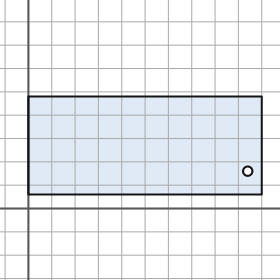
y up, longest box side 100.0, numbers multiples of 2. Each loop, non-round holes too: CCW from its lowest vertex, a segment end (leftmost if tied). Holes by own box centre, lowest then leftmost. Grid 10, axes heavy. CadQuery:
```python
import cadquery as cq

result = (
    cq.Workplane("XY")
    .moveTo(0.0, 6.0)
    .lineTo(100.0, 6.0)
    .lineTo(100.0, 48.0)
    .lineTo(0.0, 48.0)
    .close()
    .moveTo(94.0, 16.0)
    .circle(2.0)
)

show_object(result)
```